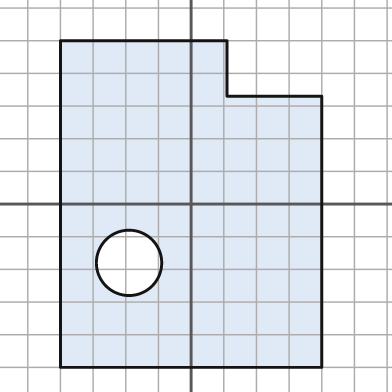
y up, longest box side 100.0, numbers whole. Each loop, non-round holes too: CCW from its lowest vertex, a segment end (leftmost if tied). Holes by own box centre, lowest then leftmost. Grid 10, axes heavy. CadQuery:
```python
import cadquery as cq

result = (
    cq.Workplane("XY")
    .moveTo(-40.0, -50.0)
    .lineTo(40.0, -50.0)
    .lineTo(40.0, 33.0)
    .lineTo(11.0, 33.0)
    .lineTo(11.0, 50.0)
    .lineTo(-40.0, 50.0)
    .close()
    .moveTo(-19.0, -18.0)
    .circle(10.0)
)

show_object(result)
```